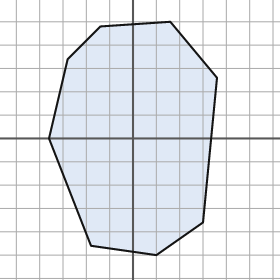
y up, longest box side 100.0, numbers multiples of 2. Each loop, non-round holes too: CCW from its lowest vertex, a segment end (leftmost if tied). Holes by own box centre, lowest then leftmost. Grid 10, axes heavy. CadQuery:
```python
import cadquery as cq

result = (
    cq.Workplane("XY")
    .moveTo(10.0, -50.0)
    .lineTo(30.0, -36.0)
    .lineTo(36.0, 26.0)
    .lineTo(16.0, 50.0)
    .lineTo(-14.0, 48.0)
    .lineTo(-28.0, 34.0)
    .lineTo(-36.0, 0.0)
    .lineTo(-18.0, -46.0)
    .close()
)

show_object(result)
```